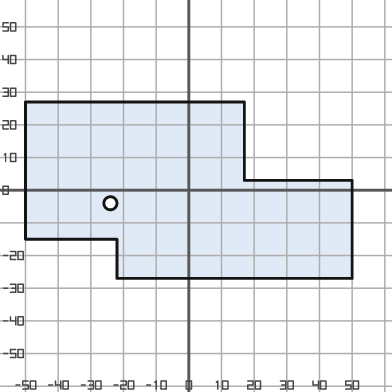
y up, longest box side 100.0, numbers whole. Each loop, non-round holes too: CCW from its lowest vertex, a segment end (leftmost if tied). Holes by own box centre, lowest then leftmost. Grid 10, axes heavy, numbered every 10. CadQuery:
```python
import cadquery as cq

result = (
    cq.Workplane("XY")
    .moveTo(-22.0, -27.0)
    .lineTo(50.0, -27.0)
    .lineTo(50.0, 3.0)
    .lineTo(17.0, 3.0)
    .lineTo(17.0, 27.0)
    .lineTo(-50.0, 27.0)
    .lineTo(-50.0, -15.0)
    .lineTo(-22.0, -15.0)
    .close()
    .moveTo(-24.0, -4.0)
    .circle(2.0)
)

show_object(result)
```